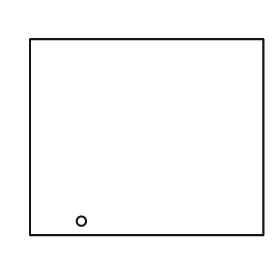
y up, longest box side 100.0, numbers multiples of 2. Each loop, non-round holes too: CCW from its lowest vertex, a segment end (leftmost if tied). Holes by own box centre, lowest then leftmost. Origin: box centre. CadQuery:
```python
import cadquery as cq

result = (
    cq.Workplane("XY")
    .moveTo(-50.0, -42.0)
    .lineTo(50.0, -42.0)
    .lineTo(50.0, 42.0)
    .lineTo(-50.0, 42.0)
    .close()
    .moveTo(-28.0, -36.0)
    .circle(2.0)
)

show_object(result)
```